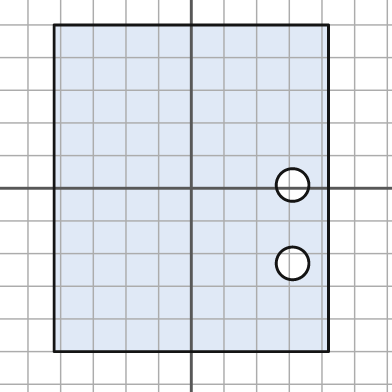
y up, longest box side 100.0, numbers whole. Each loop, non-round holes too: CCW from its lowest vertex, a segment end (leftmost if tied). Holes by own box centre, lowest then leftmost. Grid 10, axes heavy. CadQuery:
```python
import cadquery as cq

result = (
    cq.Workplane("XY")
    .moveTo(-42.0, -50.0)
    .lineTo(42.0, -50.0)
    .lineTo(42.0, 50.0)
    .lineTo(-42.0, 50.0)
    .close()
    .moveTo(31.0, -23.0)
    .circle(5.0)
    .moveTo(31.0, 1.0)
    .circle(5.0)
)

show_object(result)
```